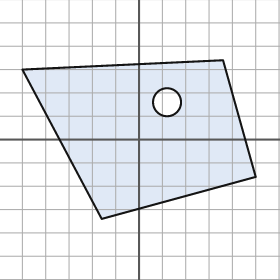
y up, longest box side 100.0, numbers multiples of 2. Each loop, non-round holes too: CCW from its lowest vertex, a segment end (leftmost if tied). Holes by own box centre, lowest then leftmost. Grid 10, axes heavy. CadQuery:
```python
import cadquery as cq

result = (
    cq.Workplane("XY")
    .moveTo(-16.0, -34.0)
    .lineTo(50.0, -16.0)
    .lineTo(36.0, 34.0)
    .lineTo(-50.0, 30.0)
    .close()
    .moveTo(12.0, 16.0)
    .circle(6.0)
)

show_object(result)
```